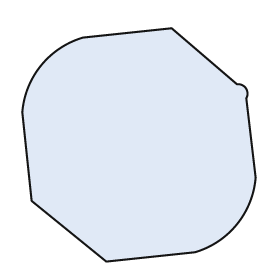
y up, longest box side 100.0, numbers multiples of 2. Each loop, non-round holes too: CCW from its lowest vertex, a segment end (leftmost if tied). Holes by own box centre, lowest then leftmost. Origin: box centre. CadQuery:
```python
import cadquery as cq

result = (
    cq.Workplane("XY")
    .moveTo(-14.0, -50.0)
    .lineTo(24.0, -46.0)
    .threePointArc((42.0, -34.0), (50.0, -14.0))
    .lineTo(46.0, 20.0)
    .threePointArc((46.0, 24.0), (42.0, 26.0))
    .lineTo(14.0, 50.0)
    .lineTo(-24.0, 46.0)
    .threePointArc((-42.0, 34.0), (-50.0, 14.0))
    .lineTo(-46.0, -24.0)
    .close()
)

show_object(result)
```